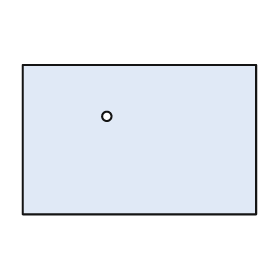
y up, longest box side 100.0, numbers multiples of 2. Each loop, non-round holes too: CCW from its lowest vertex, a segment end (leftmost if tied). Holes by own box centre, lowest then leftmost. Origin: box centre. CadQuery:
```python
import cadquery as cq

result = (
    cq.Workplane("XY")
    .moveTo(-50.0, -32.0)
    .lineTo(50.0, -32.0)
    .lineTo(50.0, 32.0)
    .lineTo(-50.0, 32.0)
    .close()
    .moveTo(-14.0, 10.0)
    .circle(2.0)
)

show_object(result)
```